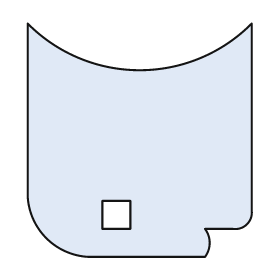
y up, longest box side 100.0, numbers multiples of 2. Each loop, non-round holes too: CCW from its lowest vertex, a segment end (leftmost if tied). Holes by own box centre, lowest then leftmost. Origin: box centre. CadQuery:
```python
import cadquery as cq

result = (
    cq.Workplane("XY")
    .moveTo(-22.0, -50.0)
    .lineTo(28.0, -50.0)
    .threePointArc((30.0, -44.0), (28.0, -38.0))
    .lineTo(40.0, -38.0)
    .threePointArc((46.0, -36.0), (48.0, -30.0))
    .lineTo(48.0, 50.0)
    .threePointArc((0.0, 30.0), (-48.0, 50.0))
    .lineTo(-48.0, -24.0)
    .threePointArc((-40.0, -42.0), (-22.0, -50.0))
    .close()
    .moveTo(-16.0, -38.0)
    .lineTo(-4.0, -38.0)
    .lineTo(-4.0, -26.0)
    .lineTo(-16.0, -26.0)
    .close()
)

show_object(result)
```